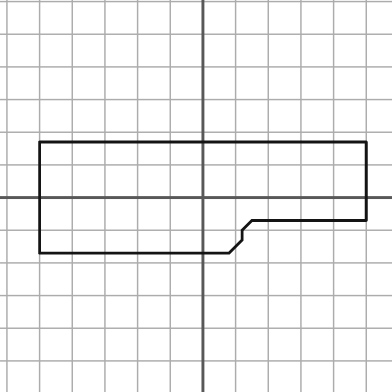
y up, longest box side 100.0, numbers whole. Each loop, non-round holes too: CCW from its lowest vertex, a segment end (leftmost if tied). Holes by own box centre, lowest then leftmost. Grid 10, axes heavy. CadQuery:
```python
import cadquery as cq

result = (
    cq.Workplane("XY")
    .moveTo(-50.0, -17.0)
    .lineTo(8.0, -17.0)
    .lineTo(12.0, -13.0)
    .lineTo(12.0, -10.0)
    .lineTo(15.0, -7.0)
    .lineTo(50.0, -7.0)
    .lineTo(50.0, 17.0)
    .lineTo(-50.0, 17.0)
    .close()
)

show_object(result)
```